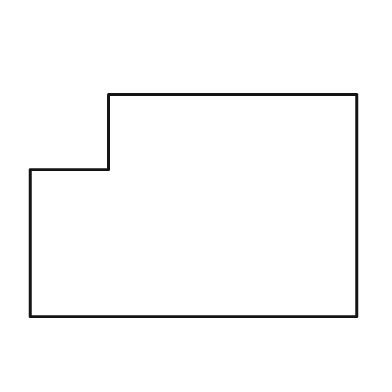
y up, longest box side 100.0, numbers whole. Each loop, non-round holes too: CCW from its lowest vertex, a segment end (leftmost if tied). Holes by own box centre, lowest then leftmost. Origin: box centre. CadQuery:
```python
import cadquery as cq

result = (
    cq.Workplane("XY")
    .moveTo(-50.0, -34.0)
    .lineTo(50.0, -34.0)
    .lineTo(50.0, 34.0)
    .lineTo(-26.0, 34.0)
    .lineTo(-26.0, 11.0)
    .lineTo(-50.0, 11.0)
    .close()
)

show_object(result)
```